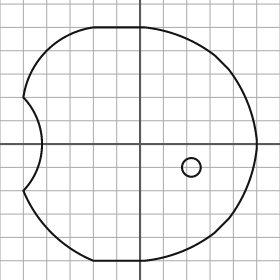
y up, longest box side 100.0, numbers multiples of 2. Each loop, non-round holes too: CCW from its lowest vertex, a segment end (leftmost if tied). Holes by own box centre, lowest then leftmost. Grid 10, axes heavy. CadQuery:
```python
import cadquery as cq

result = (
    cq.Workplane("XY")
    .moveTo(-20.0, -50.0)
    .lineTo(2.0, -50.0)
    .threePointArc((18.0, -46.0), (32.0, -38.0))
    .lineTo(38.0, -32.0)
    .threePointArc((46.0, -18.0), (50.0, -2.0))
    .lineTo(50.0, 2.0)
    .threePointArc((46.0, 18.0), (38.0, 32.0))
    .lineTo(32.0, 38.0)
    .threePointArc((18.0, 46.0), (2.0, 50.0))
    .lineTo(-20.0, 50.0)
    .threePointArc((-40.0, 40.0), (-50.0, 20.0))
    .threePointArc((-42.0, 0.0), (-50.0, -20.0))
    .threePointArc((-38.0, -38.0), (-20.0, -50.0))
    .close()
    .moveTo(22.0, -10.0)
    .circle(4.0)
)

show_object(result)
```